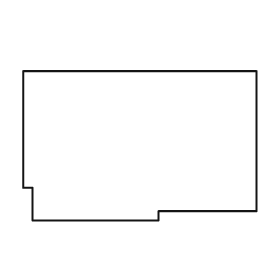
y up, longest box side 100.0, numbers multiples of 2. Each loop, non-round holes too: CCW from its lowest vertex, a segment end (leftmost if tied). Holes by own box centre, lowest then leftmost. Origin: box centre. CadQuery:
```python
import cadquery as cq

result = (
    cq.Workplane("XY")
    .moveTo(-46.0, -32.0)
    .lineTo(8.0, -32.0)
    .lineTo(8.0, -28.0)
    .lineTo(50.0, -28.0)
    .lineTo(50.0, 32.0)
    .lineTo(-50.0, 32.0)
    .lineTo(-50.0, -18.0)
    .lineTo(-46.0, -18.0)
    .close()
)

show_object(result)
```